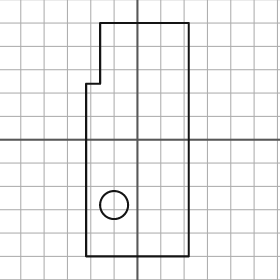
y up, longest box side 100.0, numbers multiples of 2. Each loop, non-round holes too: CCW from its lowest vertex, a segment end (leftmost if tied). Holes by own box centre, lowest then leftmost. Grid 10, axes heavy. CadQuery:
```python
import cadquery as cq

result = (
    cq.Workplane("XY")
    .moveTo(-22.0, -50.0)
    .lineTo(22.0, -50.0)
    .lineTo(22.0, 50.0)
    .lineTo(-16.0, 50.0)
    .lineTo(-16.0, 24.0)
    .lineTo(-22.0, 24.0)
    .close()
    .moveTo(-10.0, -28.0)
    .circle(6.0)
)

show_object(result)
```